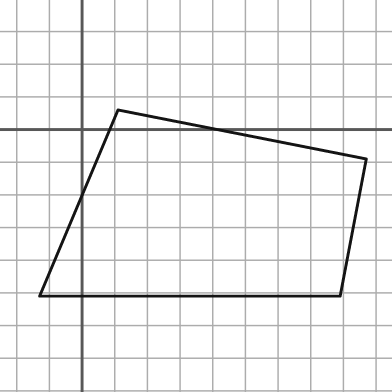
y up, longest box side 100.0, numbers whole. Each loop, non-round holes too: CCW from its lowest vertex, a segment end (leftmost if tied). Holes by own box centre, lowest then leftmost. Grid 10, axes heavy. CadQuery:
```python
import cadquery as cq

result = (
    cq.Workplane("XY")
    .moveTo(-13.0, -51.0)
    .lineTo(79.0, -51.0)
    .lineTo(87.0, -9.0)
    .lineTo(11.0, 6.0)
    .close()
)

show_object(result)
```